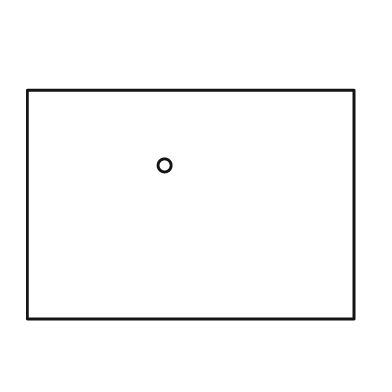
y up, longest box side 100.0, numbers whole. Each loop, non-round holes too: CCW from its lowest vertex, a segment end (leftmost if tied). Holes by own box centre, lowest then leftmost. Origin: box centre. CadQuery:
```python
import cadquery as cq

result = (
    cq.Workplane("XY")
    .moveTo(-50.0, -35.0)
    .lineTo(50.0, -35.0)
    .lineTo(50.0, 35.0)
    .lineTo(-50.0, 35.0)
    .close()
    .moveTo(-8.0, 12.0)
    .circle(2.0)
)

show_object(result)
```